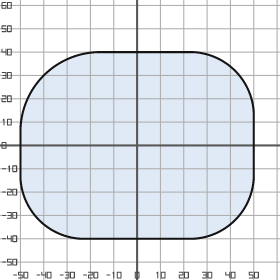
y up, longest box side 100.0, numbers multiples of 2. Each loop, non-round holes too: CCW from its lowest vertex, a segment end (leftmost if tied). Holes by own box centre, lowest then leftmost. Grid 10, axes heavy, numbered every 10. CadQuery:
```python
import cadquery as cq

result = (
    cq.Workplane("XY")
    .moveTo(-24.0, -40.0)
    .lineTo(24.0, -40.0)
    .threePointArc((42.0, -32.0), (50.0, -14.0))
    .lineTo(50.0, 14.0)
    .threePointArc((42.0, 32.0), (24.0, 40.0))
    .lineTo(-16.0, 40.0)
    .threePointArc((-40.0, 30.0), (-50.0, 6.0))
    .lineTo(-50.0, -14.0)
    .threePointArc((-42.0, -32.0), (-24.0, -40.0))
    .close()
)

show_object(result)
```